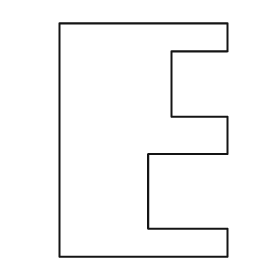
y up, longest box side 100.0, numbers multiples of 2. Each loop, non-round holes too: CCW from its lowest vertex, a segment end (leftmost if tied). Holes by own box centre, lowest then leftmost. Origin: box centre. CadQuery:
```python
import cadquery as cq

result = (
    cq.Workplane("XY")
    .moveTo(-36.0, -50.0)
    .lineTo(36.0, -50.0)
    .lineTo(36.0, -38.0)
    .lineTo(2.0, -38.0)
    .lineTo(2.0, -6.0)
    .lineTo(36.0, -6.0)
    .lineTo(36.0, 10.0)
    .lineTo(12.0, 10.0)
    .lineTo(12.0, 38.0)
    .lineTo(36.0, 38.0)
    .lineTo(36.0, 50.0)
    .lineTo(-36.0, 50.0)
    .close()
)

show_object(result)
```